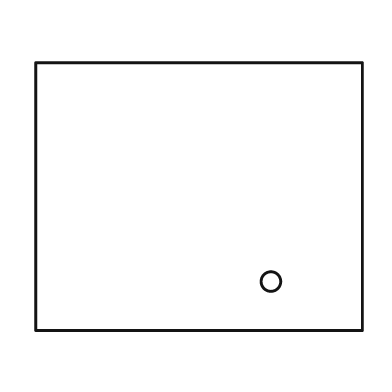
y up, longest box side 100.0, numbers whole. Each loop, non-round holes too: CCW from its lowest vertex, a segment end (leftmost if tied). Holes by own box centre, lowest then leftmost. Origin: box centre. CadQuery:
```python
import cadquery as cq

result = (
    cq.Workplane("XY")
    .moveTo(-50.0, -41.0)
    .lineTo(50.0, -41.0)
    .lineTo(50.0, 41.0)
    .lineTo(-50.0, 41.0)
    .close()
    .moveTo(22.0, -26.0)
    .circle(3.0)
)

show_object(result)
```